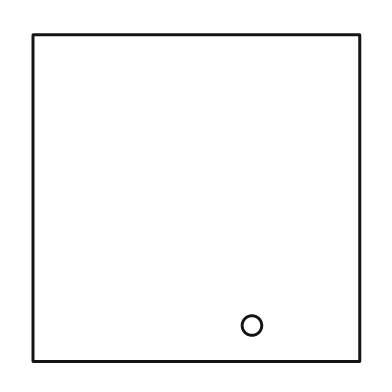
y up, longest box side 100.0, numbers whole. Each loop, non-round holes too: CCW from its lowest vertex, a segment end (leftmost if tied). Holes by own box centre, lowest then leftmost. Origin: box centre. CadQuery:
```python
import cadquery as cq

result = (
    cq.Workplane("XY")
    .moveTo(-50.0, -50.0)
    .lineTo(50.0, -50.0)
    .lineTo(50.0, 50.0)
    .lineTo(-50.0, 50.0)
    .close()
    .moveTo(17.0, -39.0)
    .circle(3.0)
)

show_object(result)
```